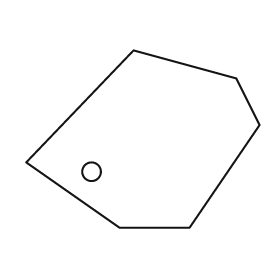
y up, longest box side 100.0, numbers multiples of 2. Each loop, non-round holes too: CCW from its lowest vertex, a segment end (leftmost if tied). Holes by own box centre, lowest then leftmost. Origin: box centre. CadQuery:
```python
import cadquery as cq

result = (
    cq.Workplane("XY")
    .moveTo(-10.0, -38.0)
    .lineTo(20.0, -38.0)
    .lineTo(50.0, 6.0)
    .lineTo(40.0, 26.0)
    .lineTo(-4.0, 38.0)
    .lineTo(-50.0, -10.0)
    .close()
    .moveTo(-22.0, -14.0)
    .circle(4.0)
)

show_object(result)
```